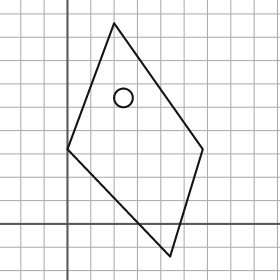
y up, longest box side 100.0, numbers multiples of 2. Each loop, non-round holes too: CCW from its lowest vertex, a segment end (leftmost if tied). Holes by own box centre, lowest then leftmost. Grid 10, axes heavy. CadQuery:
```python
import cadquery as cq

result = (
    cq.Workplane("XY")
    .moveTo(44.0, -14.0)
    .lineTo(58.0, 32.0)
    .lineTo(20.0, 86.0)
    .lineTo(0.0, 32.0)
    .close()
    .moveTo(24.0, 54.0)
    .circle(4.0)
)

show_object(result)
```